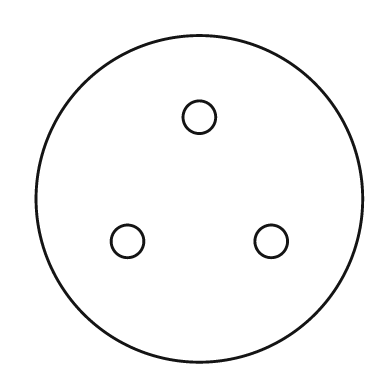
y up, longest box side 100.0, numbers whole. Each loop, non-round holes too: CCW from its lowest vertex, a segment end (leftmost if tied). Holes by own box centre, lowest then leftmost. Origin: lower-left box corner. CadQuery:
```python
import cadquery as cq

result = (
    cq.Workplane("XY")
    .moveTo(50.0, 50.0)
    .circle(50.0)
    .moveTo(28.0, 37.0)
    .circle(5.0)
    .moveTo(72.0, 37.0)
    .circle(5.0)
    .moveTo(50.0, 75.0)
    .circle(5.0)
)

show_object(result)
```